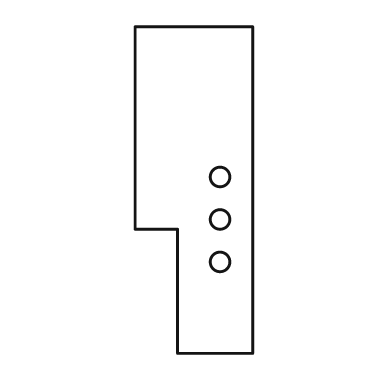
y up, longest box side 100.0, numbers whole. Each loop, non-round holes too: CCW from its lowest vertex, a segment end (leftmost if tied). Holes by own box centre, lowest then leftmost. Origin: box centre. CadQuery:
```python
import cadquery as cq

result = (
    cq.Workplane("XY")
    .moveTo(-5.0, -50.0)
    .lineTo(18.0, -50.0)
    .lineTo(18.0, 50.0)
    .lineTo(-18.0, 50.0)
    .lineTo(-18.0, -12.0)
    .lineTo(-5.0, -12.0)
    .close()
    .moveTo(8.0, -22.0)
    .circle(3.0)
    .moveTo(8.0, -9.0)
    .circle(3.0)
    .moveTo(8.0, 4.0)
    .circle(3.0)
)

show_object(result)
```